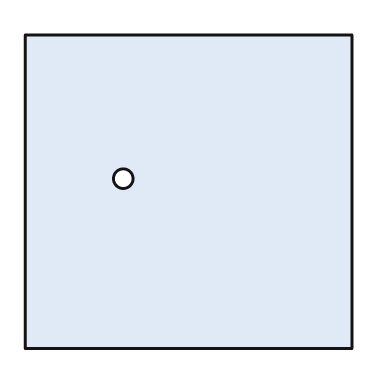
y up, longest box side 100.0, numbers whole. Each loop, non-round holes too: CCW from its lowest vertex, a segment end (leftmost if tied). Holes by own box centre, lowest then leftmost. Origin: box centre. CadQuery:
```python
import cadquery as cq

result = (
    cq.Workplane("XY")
    .moveTo(-50.0, -48.0)
    .lineTo(50.0, -48.0)
    .lineTo(50.0, 48.0)
    .lineTo(-50.0, 48.0)
    .close()
    .moveTo(-20.0, 4.0)
    .circle(3.0)
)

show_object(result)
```